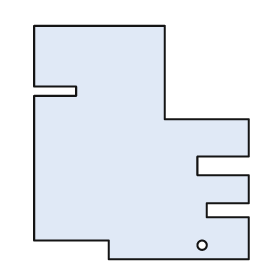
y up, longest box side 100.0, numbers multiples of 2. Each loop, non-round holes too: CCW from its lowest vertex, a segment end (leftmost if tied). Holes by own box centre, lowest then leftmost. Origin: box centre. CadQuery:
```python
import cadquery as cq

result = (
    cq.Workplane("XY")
    .moveTo(-14.0, -50.0)
    .lineTo(46.0, -50.0)
    .lineTo(46.0, -32.0)
    .lineTo(28.0, -32.0)
    .lineTo(28.0, -26.0)
    .lineTo(46.0, -26.0)
    .lineTo(46.0, -14.0)
    .lineTo(24.0, -14.0)
    .lineTo(24.0, -6.0)
    .lineTo(46.0, -6.0)
    .lineTo(46.0, 10.0)
    .lineTo(10.0, 10.0)
    .lineTo(10.0, 50.0)
    .lineTo(-46.0, 50.0)
    .lineTo(-46.0, 24.0)
    .lineTo(-28.0, 24.0)
    .lineTo(-28.0, 20.0)
    .lineTo(-46.0, 20.0)
    .lineTo(-46.0, -42.0)
    .lineTo(-14.0, -42.0)
    .close()
    .moveTo(26.0, -44.0)
    .circle(2.0)
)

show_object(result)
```